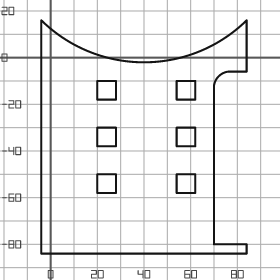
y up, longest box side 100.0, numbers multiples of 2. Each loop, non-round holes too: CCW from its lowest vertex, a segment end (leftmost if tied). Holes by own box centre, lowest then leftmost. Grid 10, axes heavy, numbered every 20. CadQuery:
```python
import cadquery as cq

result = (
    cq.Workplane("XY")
    .moveTo(-4.0, -84.0)
    .lineTo(84.0, -84.0)
    .lineTo(84.0, -80.0)
    .lineTo(70.0, -80.0)
    .lineTo(70.0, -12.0)
    .threePointArc((72.0, -8.0), (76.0, -6.0))
    .lineTo(84.0, -6.0)
    .lineTo(84.0, 16.0)
    .threePointArc((40.0, -2.0), (-4.0, 16.0))
    .close()
    .moveTo(20.0, -58.0)
    .lineTo(28.0, -58.0)
    .lineTo(28.0, -50.0)
    .lineTo(20.0, -50.0)
    .close()
    .moveTo(54.0, -58.0)
    .lineTo(62.0, -58.0)
    .lineTo(62.0, -50.0)
    .lineTo(54.0, -50.0)
    .close()
    .moveTo(20.0, -38.0)
    .lineTo(28.0, -38.0)
    .lineTo(28.0, -30.0)
    .lineTo(20.0, -30.0)
    .close()
    .moveTo(54.0, -38.0)
    .lineTo(62.0, -38.0)
    .lineTo(62.0, -30.0)
    .lineTo(54.0, -30.0)
    .close()
    .moveTo(20.0, -18.0)
    .lineTo(28.0, -18.0)
    .lineTo(28.0, -10.0)
    .lineTo(20.0, -10.0)
    .close()
    .moveTo(54.0, -18.0)
    .lineTo(62.0, -18.0)
    .lineTo(62.0, -10.0)
    .lineTo(54.0, -10.0)
    .close()
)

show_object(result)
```